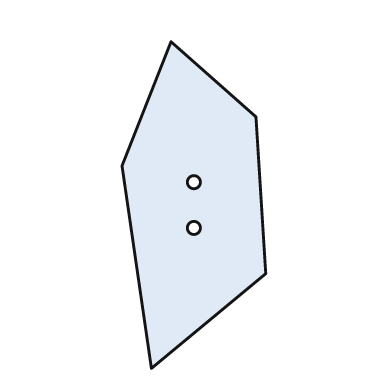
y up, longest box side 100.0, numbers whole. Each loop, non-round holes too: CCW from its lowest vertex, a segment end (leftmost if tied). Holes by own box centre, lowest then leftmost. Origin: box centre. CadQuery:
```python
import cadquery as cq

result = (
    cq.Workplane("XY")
    .moveTo(-13.0, -50.0)
    .lineTo(22.0, -21.0)
    .lineTo(19.0, 27.0)
    .lineTo(-7.0, 50.0)
    .lineTo(-22.0, 12.0)
    .close()
    .moveTo(0.0, -7.0)
    .circle(2.0)
    .moveTo(0.0, 7.0)
    .circle(2.0)
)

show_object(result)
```